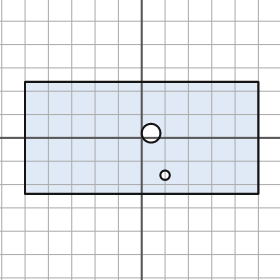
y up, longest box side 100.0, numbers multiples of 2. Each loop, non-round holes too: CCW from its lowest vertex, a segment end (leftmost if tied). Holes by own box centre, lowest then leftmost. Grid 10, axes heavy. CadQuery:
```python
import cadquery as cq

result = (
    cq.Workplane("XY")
    .moveTo(-50.0, -24.0)
    .lineTo(50.0, -24.0)
    .lineTo(50.0, 24.0)
    .lineTo(-50.0, 24.0)
    .close()
    .moveTo(10.0, -16.0)
    .circle(2.0)
    .moveTo(4.0, 2.0)
    .circle(4.0)
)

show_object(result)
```